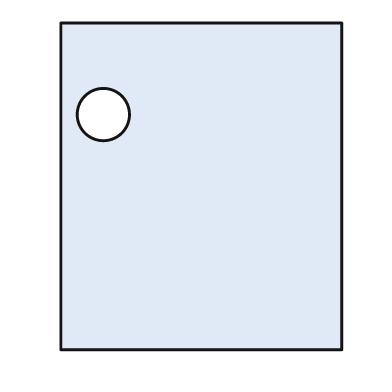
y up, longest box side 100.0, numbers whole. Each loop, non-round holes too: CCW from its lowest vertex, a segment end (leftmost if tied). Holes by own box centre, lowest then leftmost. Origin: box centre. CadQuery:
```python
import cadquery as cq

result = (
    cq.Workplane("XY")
    .moveTo(-43.0, -50.0)
    .lineTo(43.0, -50.0)
    .lineTo(43.0, 50.0)
    .lineTo(-43.0, 50.0)
    .close()
    .moveTo(-30.0, 22.0)
    .circle(8.0)
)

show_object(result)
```